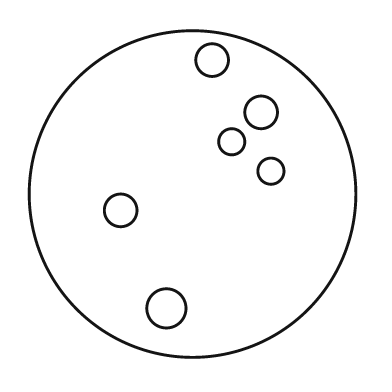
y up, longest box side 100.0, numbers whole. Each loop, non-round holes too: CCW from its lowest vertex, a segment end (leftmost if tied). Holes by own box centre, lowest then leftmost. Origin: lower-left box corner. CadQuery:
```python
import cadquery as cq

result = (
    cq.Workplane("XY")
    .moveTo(50.0, 50.0)
    .circle(50.0)
    .moveTo(42.0, 15.0)
    .circle(6.0)
    .moveTo(28.0, 45.0)
    .circle(5.0)
    .moveTo(74.0, 57.0)
    .circle(4.0)
    .moveTo(62.0, 66.0)
    .circle(4.0)
    .moveTo(71.0, 75.0)
    .circle(5.0)
    .moveTo(56.0, 91.0)
    .circle(5.0)
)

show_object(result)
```